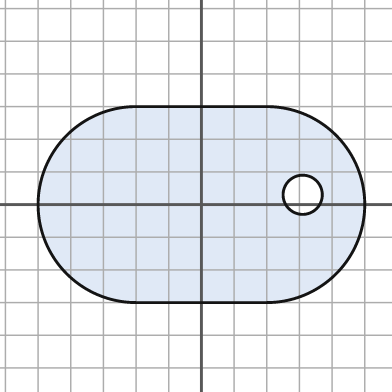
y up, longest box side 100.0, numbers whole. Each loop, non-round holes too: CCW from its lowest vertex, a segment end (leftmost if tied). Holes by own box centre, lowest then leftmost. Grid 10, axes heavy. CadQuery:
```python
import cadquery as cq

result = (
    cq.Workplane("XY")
    .moveTo(-20.0, -30.0)
    .lineTo(20.0, -30.0)
    .threePointArc((50.0, 0.0), (20.0, 30.0))
    .lineTo(-20.0, 30.0)
    .threePointArc((-50.0, 0.0), (-20.0, -30.0))
    .close()
    .moveTo(31.0, 3.0)
    .circle(6.0)
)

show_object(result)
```